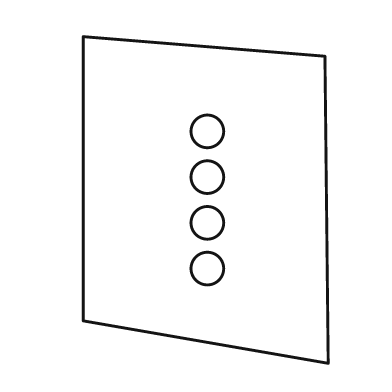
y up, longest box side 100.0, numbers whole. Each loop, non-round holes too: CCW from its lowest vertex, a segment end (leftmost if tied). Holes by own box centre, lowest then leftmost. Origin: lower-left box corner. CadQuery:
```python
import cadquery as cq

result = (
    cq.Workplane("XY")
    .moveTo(75.0, 0.0)
    .lineTo(74.0, 94.0)
    .lineTo(0.0, 100.0)
    .lineTo(0.0, 13.0)
    .close()
    .moveTo(38.0, 29.0)
    .circle(5.0)
    .moveTo(38.0, 43.0)
    .circle(5.0)
    .moveTo(38.0, 57.0)
    .circle(5.0)
    .moveTo(38.0, 71.0)
    .circle(5.0)
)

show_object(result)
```